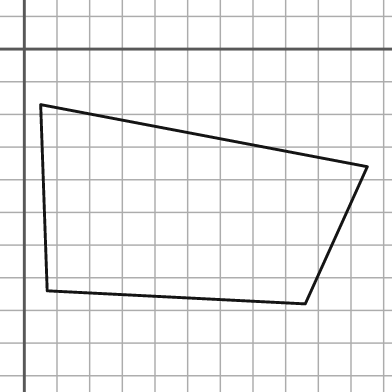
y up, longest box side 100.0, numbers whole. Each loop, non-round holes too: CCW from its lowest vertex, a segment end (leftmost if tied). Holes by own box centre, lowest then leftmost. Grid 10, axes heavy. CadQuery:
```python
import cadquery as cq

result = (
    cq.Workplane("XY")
    .moveTo(86.0, -78.0)
    .lineTo(105.0, -36.0)
    .lineTo(5.0, -17.0)
    .lineTo(7.0, -74.0)
    .close()
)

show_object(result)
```